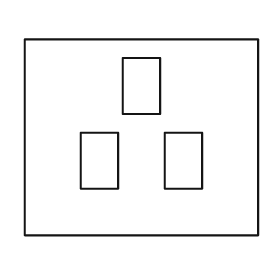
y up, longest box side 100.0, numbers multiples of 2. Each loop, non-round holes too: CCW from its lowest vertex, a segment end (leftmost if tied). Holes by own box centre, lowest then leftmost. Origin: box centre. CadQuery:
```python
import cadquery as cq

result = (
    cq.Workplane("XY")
    .moveTo(-50.0, -42.0)
    .lineTo(50.0, -42.0)
    .lineTo(50.0, 42.0)
    .lineTo(-50.0, 42.0)
    .close()
    .moveTo(-26.0, -22.0)
    .lineTo(-10.0, -22.0)
    .lineTo(-10.0, 2.0)
    .lineTo(-26.0, 2.0)
    .close()
    .moveTo(10.0, -22.0)
    .lineTo(26.0, -22.0)
    .lineTo(26.0, 2.0)
    .lineTo(10.0, 2.0)
    .close()
    .moveTo(-8.0, 10.0)
    .lineTo(8.0, 10.0)
    .lineTo(8.0, 34.0)
    .lineTo(-8.0, 34.0)
    .close()
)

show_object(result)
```